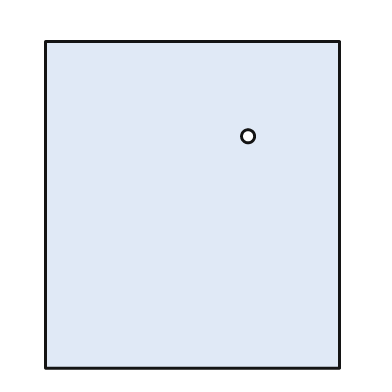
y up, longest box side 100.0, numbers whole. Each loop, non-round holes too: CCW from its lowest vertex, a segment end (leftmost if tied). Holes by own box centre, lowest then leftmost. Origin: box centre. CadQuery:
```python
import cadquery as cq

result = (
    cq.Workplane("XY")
    .moveTo(-45.0, -50.0)
    .lineTo(45.0, -50.0)
    .lineTo(45.0, 50.0)
    .lineTo(-45.0, 50.0)
    .close()
    .moveTo(17.0, 21.0)
    .circle(2.0)
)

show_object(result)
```